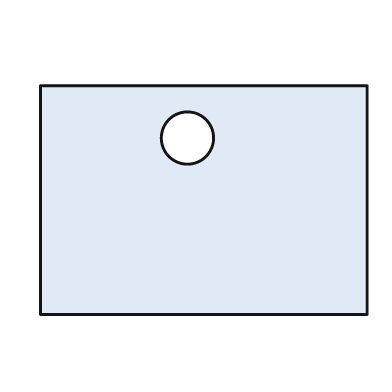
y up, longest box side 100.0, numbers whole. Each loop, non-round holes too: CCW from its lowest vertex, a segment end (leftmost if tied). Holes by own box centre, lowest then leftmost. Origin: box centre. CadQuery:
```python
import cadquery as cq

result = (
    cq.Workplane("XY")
    .moveTo(-50.0, -35.0)
    .lineTo(50.0, -35.0)
    .lineTo(50.0, 35.0)
    .lineTo(-50.0, 35.0)
    .close()
    .moveTo(-5.0, 19.0)
    .circle(8.0)
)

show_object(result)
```